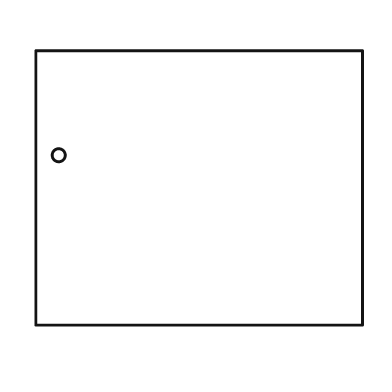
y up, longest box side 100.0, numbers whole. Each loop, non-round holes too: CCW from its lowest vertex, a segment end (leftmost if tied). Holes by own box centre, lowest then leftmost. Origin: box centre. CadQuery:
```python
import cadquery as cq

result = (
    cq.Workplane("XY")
    .moveTo(-50.0, -42.0)
    .lineTo(50.0, -42.0)
    .lineTo(50.0, 42.0)
    .lineTo(-50.0, 42.0)
    .close()
    .moveTo(-43.0, 10.0)
    .circle(2.0)
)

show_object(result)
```